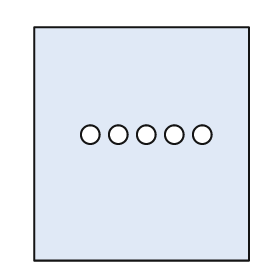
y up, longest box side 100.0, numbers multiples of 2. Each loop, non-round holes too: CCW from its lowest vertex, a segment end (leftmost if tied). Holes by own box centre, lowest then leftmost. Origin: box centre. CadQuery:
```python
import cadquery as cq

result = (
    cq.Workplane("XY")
    .moveTo(-46.0, -50.0)
    .lineTo(46.0, -50.0)
    .lineTo(46.0, 50.0)
    .lineTo(-46.0, 50.0)
    .close()
    .moveTo(-22.0, 4.0)
    .circle(4.0)
    .moveTo(-10.0, 4.0)
    .circle(4.0)
    .moveTo(2.0, 4.0)
    .circle(4.0)
    .moveTo(14.0, 4.0)
    .circle(4.0)
    .moveTo(26.0, 4.0)
    .circle(4.0)
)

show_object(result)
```